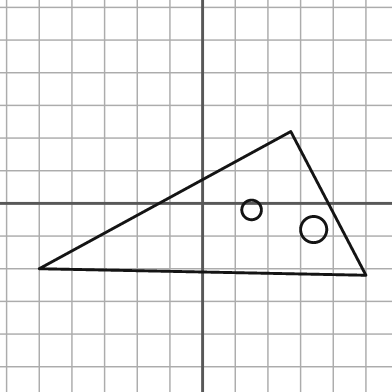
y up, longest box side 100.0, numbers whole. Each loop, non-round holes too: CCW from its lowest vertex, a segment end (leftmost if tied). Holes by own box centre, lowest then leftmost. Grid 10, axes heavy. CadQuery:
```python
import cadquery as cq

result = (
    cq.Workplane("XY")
    .moveTo(50.0, -22.0)
    .lineTo(27.0, 22.0)
    .lineTo(-50.0, -20.0)
    .close()
    .moveTo(34.0, -8.0)
    .circle(4.0)
    .moveTo(15.0, -2.0)
    .circle(3.0)
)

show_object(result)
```